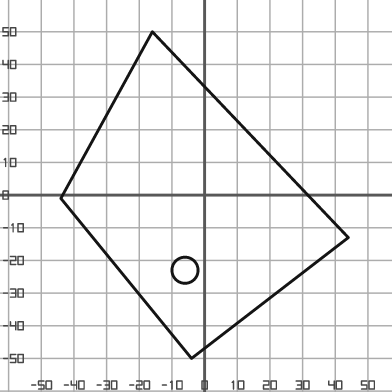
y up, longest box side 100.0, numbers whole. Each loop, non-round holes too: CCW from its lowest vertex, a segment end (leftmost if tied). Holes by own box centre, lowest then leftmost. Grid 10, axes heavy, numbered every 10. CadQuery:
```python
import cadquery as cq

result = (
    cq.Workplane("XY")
    .moveTo(-4.0, -50.0)
    .lineTo(44.0, -13.0)
    .lineTo(-16.0, 50.0)
    .lineTo(-44.0, -1.0)
    .close()
    .moveTo(-6.0, -23.0)
    .circle(4.0)
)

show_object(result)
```